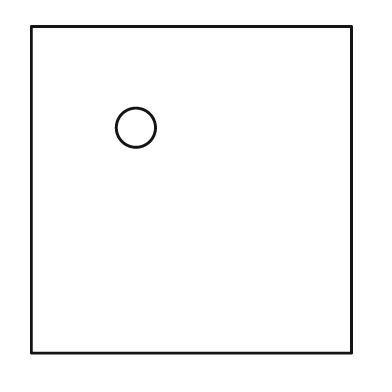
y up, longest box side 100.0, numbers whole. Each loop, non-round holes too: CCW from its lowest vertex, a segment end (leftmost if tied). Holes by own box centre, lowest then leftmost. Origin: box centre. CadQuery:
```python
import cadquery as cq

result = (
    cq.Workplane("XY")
    .moveTo(-49.0, -50.0)
    .lineTo(49.0, -50.0)
    .lineTo(49.0, 50.0)
    .lineTo(-49.0, 50.0)
    .close()
    .moveTo(-17.0, 19.0)
    .circle(6.0)
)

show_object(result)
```